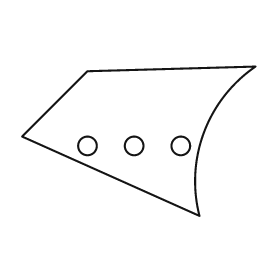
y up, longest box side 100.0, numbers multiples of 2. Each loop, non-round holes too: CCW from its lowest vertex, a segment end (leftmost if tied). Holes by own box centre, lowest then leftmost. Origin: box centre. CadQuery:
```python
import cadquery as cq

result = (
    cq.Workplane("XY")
    .moveTo(26.0, -32.0)
    .threePointArc((28.0, 4.0), (50.0, 32.0))
    .lineTo(-22.0, 30.0)
    .lineTo(-50.0, 2.0)
    .close()
    .moveTo(-22.0, -2.0)
    .circle(4.0)
    .moveTo(-2.0, -2.0)
    .circle(4.0)
    .moveTo(18.0, -2.0)
    .circle(4.0)
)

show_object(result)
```